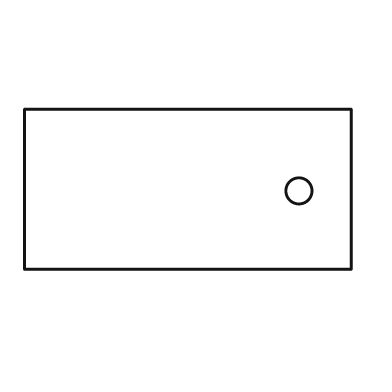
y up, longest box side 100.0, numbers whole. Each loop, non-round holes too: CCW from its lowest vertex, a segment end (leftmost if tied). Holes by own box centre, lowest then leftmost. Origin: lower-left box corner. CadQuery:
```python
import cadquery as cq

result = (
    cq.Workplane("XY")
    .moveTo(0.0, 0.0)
    .lineTo(100.0, 0.0)
    .lineTo(100.0, 49.0)
    .lineTo(0.0, 49.0)
    .close()
    .moveTo(84.0, 24.0)
    .circle(4.0)
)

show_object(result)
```